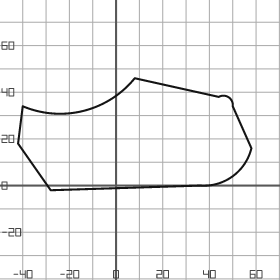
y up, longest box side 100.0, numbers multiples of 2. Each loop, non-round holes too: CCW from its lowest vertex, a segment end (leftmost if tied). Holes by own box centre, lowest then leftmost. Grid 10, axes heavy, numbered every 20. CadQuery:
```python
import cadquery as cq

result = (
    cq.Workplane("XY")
    .moveTo(-28.0, -2.0)
    .lineTo(36.0, 0.0)
    .threePointArc((50.0, 4.0), (58.0, 16.0))
    .lineTo(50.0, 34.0)
    .threePointArc((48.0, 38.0), (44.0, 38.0))
    .lineTo(8.0, 46.0)
    .threePointArc((-14.0, 32.0), (-40.0, 34.0))
    .lineTo(-42.0, 18.0)
    .close()
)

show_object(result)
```